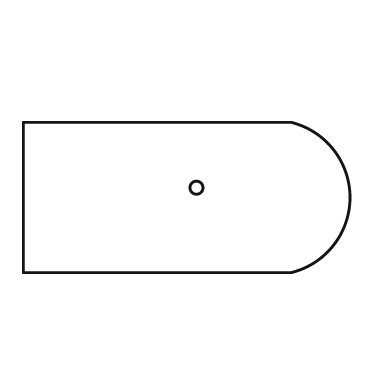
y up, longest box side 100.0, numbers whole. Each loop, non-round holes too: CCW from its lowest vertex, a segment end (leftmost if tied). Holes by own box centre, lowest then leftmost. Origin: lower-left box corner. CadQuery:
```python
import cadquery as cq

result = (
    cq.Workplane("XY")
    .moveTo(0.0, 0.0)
    .lineTo(82.0, 0.0)
    .threePointArc((100.0, 23.0), (82.0, 46.0))
    .lineTo(0.0, 46.0)
    .close()
    .moveTo(53.0, 26.0)
    .circle(2.0)
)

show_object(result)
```